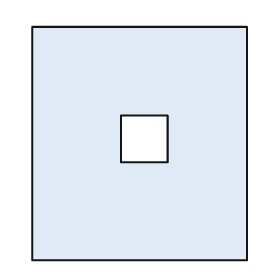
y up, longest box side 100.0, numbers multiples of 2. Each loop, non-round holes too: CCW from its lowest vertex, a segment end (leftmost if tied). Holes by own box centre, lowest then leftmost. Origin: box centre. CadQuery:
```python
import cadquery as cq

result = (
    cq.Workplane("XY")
    .moveTo(-46.0, -50.0)
    .lineTo(46.0, -50.0)
    .lineTo(46.0, 50.0)
    .lineTo(-46.0, 50.0)
    .close()
    .moveTo(-8.0, -8.0)
    .lineTo(12.0, -8.0)
    .lineTo(12.0, 12.0)
    .lineTo(-8.0, 12.0)
    .close()
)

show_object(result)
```